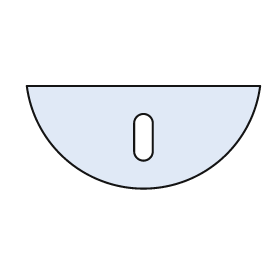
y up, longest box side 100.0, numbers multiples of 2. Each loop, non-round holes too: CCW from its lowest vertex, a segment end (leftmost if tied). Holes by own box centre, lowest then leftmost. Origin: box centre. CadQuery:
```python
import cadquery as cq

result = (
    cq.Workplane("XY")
    .moveTo(-50.0, 22.0)
    .threePointArc((0.0, -22.0), (50.0, 22.0))
    .close()
    .moveTo(-4.0, -6.0)
    .threePointArc((0.0, -10.0), (4.0, -6.0))
    .lineTo(4.0, 6.0)
    .threePointArc((0.0, 10.0), (-4.0, 6.0))
    .close()
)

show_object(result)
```